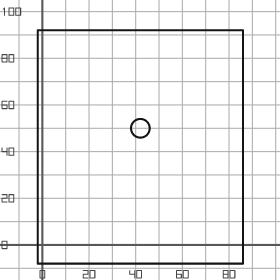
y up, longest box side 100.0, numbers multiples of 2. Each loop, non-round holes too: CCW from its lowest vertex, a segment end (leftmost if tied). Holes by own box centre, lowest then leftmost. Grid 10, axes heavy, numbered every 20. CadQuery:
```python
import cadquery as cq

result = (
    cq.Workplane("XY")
    .moveTo(-2.0, -8.0)
    .lineTo(86.0, -8.0)
    .lineTo(86.0, 92.0)
    .lineTo(-2.0, 92.0)
    .close()
    .moveTo(42.0, 50.0)
    .circle(4.0)
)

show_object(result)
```